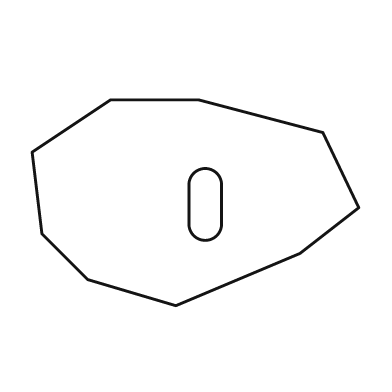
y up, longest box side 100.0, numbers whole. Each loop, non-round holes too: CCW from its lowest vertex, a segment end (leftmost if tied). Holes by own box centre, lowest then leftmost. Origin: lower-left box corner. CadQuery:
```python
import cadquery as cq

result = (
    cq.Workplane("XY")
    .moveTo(44.0, 0.0)
    .lineTo(82.0, 16.0)
    .lineTo(100.0, 30.0)
    .lineTo(89.0, 53.0)
    .lineTo(51.0, 63.0)
    .lineTo(24.0, 63.0)
    .lineTo(0.0, 47.0)
    .lineTo(3.0, 22.0)
    .lineTo(17.0, 8.0)
    .close()
    .moveTo(48.0, 25.0)
    .threePointArc((53.0, 20.0), (58.0, 25.0))
    .lineTo(58.0, 37.0)
    .threePointArc((53.0, 42.0), (48.0, 37.0))
    .close()
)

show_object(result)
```